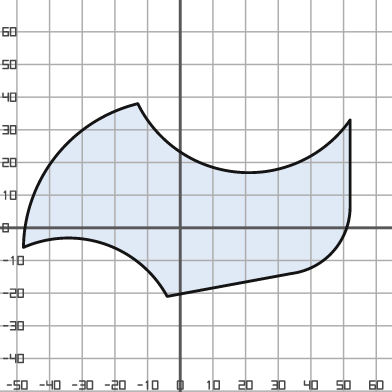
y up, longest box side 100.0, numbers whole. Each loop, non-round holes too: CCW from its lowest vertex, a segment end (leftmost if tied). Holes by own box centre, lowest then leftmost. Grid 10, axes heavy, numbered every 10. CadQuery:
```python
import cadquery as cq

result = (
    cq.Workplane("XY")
    .moveTo(-4.0, -21.0)
    .lineTo(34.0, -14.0)
    .threePointArc((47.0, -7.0), (52.0, 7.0))
    .lineTo(52.0, 33.0)
    .threePointArc((18.0, 17.0), (-13.0, 38.0))
    .threePointArc((-38.0, 22.0), (-48.0, -6.0))
    .threePointArc((-23.0, -5.0), (-4.0, -21.0))
    .close()
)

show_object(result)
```